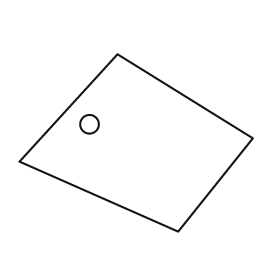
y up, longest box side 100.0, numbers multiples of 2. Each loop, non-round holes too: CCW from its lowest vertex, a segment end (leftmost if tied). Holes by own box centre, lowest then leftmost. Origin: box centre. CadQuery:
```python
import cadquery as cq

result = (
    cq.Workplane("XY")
    .moveTo(18.0, -38.0)
    .lineTo(50.0, 2.0)
    .lineTo(-8.0, 38.0)
    .lineTo(-50.0, -8.0)
    .close()
    .moveTo(-20.0, 8.0)
    .circle(4.0)
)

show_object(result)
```